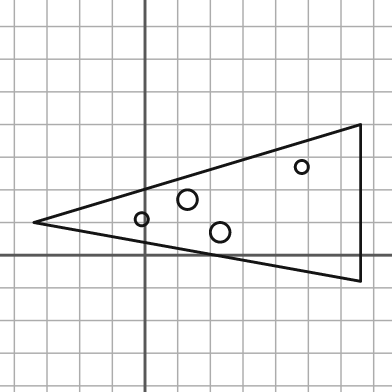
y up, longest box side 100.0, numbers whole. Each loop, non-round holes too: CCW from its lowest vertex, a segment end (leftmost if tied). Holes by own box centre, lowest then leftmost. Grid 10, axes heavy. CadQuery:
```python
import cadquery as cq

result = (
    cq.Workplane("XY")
    .moveTo(66.0, -8.0)
    .lineTo(66.0, 40.0)
    .lineTo(-34.0, 10.0)
    .close()
    .moveTo(23.0, 7.0)
    .circle(3.0)
    .moveTo(-1.0, 11.0)
    .circle(2.0)
    .moveTo(13.0, 17.0)
    .circle(3.0)
    .moveTo(48.0, 27.0)
    .circle(2.0)
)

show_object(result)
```